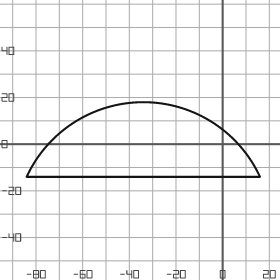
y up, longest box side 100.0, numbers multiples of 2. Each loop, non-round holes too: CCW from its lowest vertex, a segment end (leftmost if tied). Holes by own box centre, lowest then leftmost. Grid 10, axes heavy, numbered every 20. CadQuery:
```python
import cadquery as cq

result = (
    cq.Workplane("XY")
    .moveTo(-84.0, -14.0)
    .lineTo(16.0, -14.0)
    .threePointArc((-34.0, 18.0), (-84.0, -14.0))
    .close()
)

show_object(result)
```